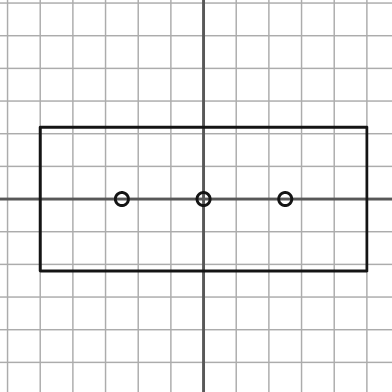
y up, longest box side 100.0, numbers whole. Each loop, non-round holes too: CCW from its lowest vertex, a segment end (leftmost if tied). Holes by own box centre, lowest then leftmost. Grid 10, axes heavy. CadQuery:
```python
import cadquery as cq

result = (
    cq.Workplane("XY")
    .moveTo(-50.0, -22.0)
    .lineTo(50.0, -22.0)
    .lineTo(50.0, 22.0)
    .lineTo(-50.0, 22.0)
    .close()
    .moveTo(-25.0, 0.0)
    .circle(2.0)
    .moveTo(0.0, 0.0)
    .circle(2.0)
    .moveTo(25.0, 0.0)
    .circle(2.0)
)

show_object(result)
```